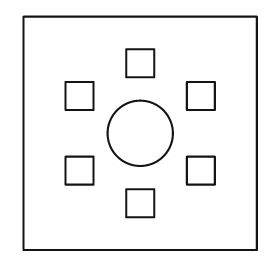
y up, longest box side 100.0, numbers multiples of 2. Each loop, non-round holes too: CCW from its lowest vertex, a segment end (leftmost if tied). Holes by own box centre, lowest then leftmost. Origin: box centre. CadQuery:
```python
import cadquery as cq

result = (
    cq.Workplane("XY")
    .moveTo(-50.0, -50.0)
    .lineTo(50.0, -50.0)
    .lineTo(50.0, 50.0)
    .lineTo(-50.0, 50.0)
    .close()
    .moveTo(-6.0, -36.0)
    .lineTo(6.0, -36.0)
    .lineTo(6.0, -24.0)
    .lineTo(-6.0, -24.0)
    .close()
    .moveTo(-32.0, -22.0)
    .lineTo(-20.0, -22.0)
    .lineTo(-20.0, -10.0)
    .lineTo(-32.0, -10.0)
    .close()
    .moveTo(20.0, -22.0)
    .lineTo(32.0, -22.0)
    .lineTo(32.0, -10.0)
    .lineTo(20.0, -10.0)
    .close()
    .moveTo(0.0, 0.0)
    .circle(14.0)
    .moveTo(-32.0, 10.0)
    .lineTo(-20.0, 10.0)
    .lineTo(-20.0, 22.0)
    .lineTo(-32.0, 22.0)
    .close()
    .moveTo(20.0, 10.0)
    .lineTo(32.0, 10.0)
    .lineTo(32.0, 22.0)
    .lineTo(20.0, 22.0)
    .close()
    .moveTo(-6.0, 24.0)
    .lineTo(6.0, 24.0)
    .lineTo(6.0, 36.0)
    .lineTo(-6.0, 36.0)
    .close()
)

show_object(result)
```